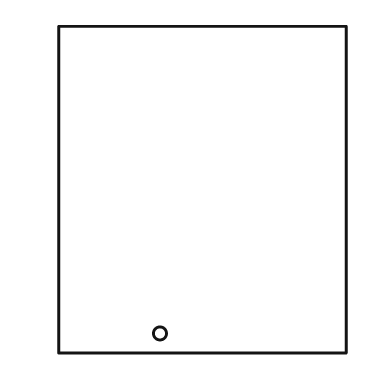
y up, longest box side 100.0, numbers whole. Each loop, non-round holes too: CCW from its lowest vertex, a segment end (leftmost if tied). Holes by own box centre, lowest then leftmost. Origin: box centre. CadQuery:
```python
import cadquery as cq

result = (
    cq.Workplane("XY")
    .moveTo(-44.0, -50.0)
    .lineTo(44.0, -50.0)
    .lineTo(44.0, 50.0)
    .lineTo(-44.0, 50.0)
    .close()
    .moveTo(-13.0, -44.0)
    .circle(2.0)
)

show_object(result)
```